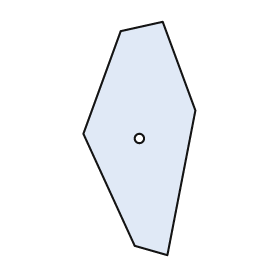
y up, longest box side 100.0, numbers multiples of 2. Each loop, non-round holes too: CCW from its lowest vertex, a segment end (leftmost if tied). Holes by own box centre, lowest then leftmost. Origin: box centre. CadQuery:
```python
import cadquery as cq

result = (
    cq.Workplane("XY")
    .moveTo(12.0, -50.0)
    .lineTo(24.0, 12.0)
    .lineTo(10.0, 50.0)
    .lineTo(-8.0, 46.0)
    .lineTo(-24.0, 2.0)
    .lineTo(-2.0, -46.0)
    .close()
    .moveTo(0.0, 0.0)
    .circle(2.0)
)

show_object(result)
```